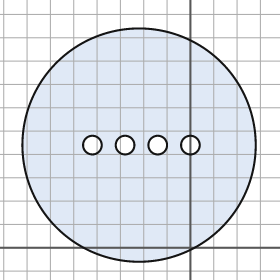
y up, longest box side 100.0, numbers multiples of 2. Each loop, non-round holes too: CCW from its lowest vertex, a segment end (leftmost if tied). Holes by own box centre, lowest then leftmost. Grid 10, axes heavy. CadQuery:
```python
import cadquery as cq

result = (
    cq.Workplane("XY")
    .moveTo(-22.0, 44.0)
    .circle(50.0)
    .moveTo(-42.0, 44.0)
    .circle(4.0)
    .moveTo(-28.0, 44.0)
    .circle(4.0)
    .moveTo(-14.0, 44.0)
    .circle(4.0)
    .moveTo(0.0, 44.0)
    .circle(4.0)
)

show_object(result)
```